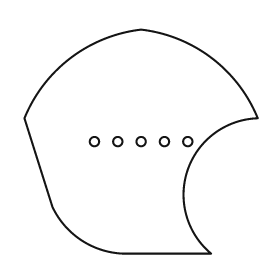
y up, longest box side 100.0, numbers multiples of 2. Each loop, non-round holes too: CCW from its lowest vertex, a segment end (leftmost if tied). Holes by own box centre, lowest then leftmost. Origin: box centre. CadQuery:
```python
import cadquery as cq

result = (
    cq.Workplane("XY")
    .moveTo(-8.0, -48.0)
    .lineTo(30.0, -48.0)
    .threePointArc((20.0, -12.0), (50.0, 10.0))
    .threePointArc((30.0, 36.0), (0.0, 48.0))
    .threePointArc((-30.0, 36.0), (-50.0, 10.0))
    .lineTo(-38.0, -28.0)
    .threePointArc((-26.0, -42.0), (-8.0, -48.0))
    .close()
    .moveTo(-20.0, 0.0)
    .circle(2.0)
    .moveTo(-10.0, 0.0)
    .circle(2.0)
    .moveTo(0.0, 0.0)
    .circle(2.0)
    .moveTo(10.0, 0.0)
    .circle(2.0)
    .moveTo(20.0, 0.0)
    .circle(2.0)
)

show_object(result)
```